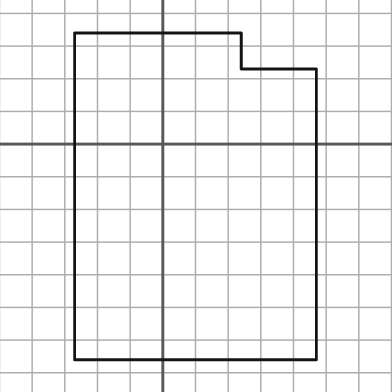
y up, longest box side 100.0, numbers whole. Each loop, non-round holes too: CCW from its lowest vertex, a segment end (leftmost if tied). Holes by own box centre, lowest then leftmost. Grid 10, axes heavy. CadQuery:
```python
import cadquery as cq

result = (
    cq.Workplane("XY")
    .moveTo(-27.0, -66.0)
    .lineTo(47.0, -66.0)
    .lineTo(47.0, 23.0)
    .lineTo(24.0, 23.0)
    .lineTo(24.0, 34.0)
    .lineTo(-27.0, 34.0)
    .close()
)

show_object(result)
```